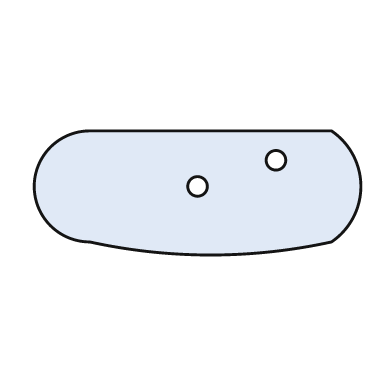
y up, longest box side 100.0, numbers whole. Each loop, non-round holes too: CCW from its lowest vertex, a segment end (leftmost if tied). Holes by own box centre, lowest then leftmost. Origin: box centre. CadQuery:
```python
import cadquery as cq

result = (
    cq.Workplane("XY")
    .moveTo(-33.0, -15.0)
    .threePointArc((4.0, -19.0), (41.0, -15.0))
    .threePointArc((50.0, 2.0), (41.0, 19.0))
    .lineTo(-33.0, 19.0)
    .threePointArc((-50.0, 2.0), (-33.0, -15.0))
    .close()
    .moveTo(0.0, 2.0)
    .circle(3.0)
    .moveTo(24.0, 10.0)
    .circle(3.0)
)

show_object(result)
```